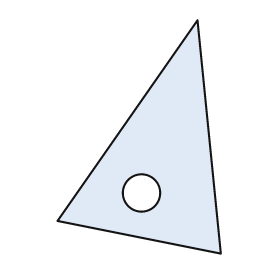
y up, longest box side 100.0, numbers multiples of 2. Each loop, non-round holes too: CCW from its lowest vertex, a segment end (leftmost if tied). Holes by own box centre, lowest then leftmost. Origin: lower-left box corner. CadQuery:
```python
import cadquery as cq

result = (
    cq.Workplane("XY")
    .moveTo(70.0, 0.0)
    .lineTo(60.0, 100.0)
    .lineTo(0.0, 14.0)
    .close()
    .moveTo(36.0, 26.0)
    .circle(8.0)
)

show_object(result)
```